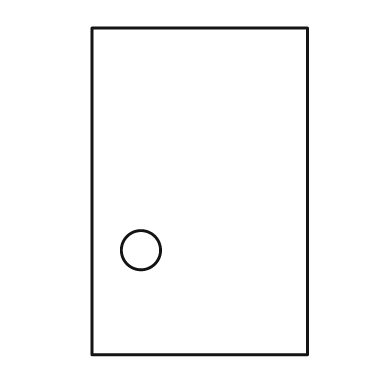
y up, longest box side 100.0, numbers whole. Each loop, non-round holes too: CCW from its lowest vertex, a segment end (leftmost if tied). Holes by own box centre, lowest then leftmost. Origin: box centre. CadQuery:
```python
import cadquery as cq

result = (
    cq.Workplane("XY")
    .moveTo(-33.0, -50.0)
    .lineTo(33.0, -50.0)
    .lineTo(33.0, 50.0)
    .lineTo(-33.0, 50.0)
    .close()
    .moveTo(-18.0, -18.0)
    .circle(6.0)
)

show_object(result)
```